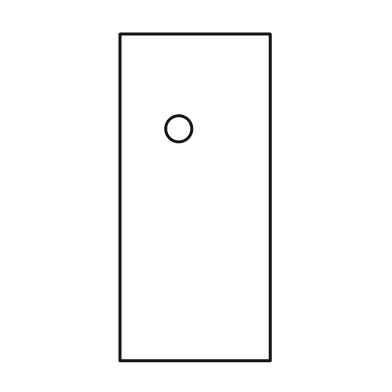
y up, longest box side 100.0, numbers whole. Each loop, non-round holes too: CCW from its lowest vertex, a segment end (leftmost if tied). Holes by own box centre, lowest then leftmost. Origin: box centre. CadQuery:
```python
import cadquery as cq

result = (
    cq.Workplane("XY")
    .moveTo(-23.0, -50.0)
    .lineTo(23.0, -50.0)
    .lineTo(23.0, 50.0)
    .lineTo(-23.0, 50.0)
    .close()
    .moveTo(-5.0, 21.0)
    .circle(4.0)
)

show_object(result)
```